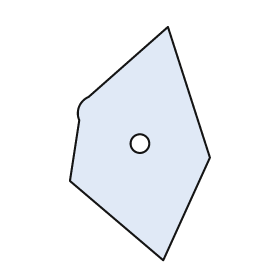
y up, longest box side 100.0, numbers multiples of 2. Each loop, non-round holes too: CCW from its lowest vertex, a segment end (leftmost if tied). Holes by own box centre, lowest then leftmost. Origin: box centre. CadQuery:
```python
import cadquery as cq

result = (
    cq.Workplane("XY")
    .moveTo(10.0, -50.0)
    .lineTo(30.0, -6.0)
    .lineTo(12.0, 50.0)
    .lineTo(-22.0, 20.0)
    .threePointArc((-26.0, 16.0), (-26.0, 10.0))
    .lineTo(-30.0, -16.0)
    .close()
    .moveTo(0.0, 0.0)
    .circle(4.0)
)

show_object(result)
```